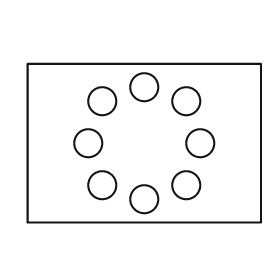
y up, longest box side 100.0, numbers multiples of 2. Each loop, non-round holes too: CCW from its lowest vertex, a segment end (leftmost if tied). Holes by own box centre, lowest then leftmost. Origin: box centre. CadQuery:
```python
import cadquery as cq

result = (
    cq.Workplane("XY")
    .moveTo(-50.0, -34.0)
    .lineTo(50.0, -34.0)
    .lineTo(50.0, 34.0)
    .lineTo(-50.0, 34.0)
    .close()
    .moveTo(0.0, -24.0)
    .circle(6.0)
    .moveTo(-18.0, -18.0)
    .circle(6.0)
    .moveTo(18.0, -18.0)
    .circle(6.0)
    .moveTo(-24.0, 0.0)
    .circle(6.0)
    .moveTo(24.0, 0.0)
    .circle(6.0)
    .moveTo(-18.0, 18.0)
    .circle(6.0)
    .moveTo(18.0, 18.0)
    .circle(6.0)
    .moveTo(0.0, 24.0)
    .circle(6.0)
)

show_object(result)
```